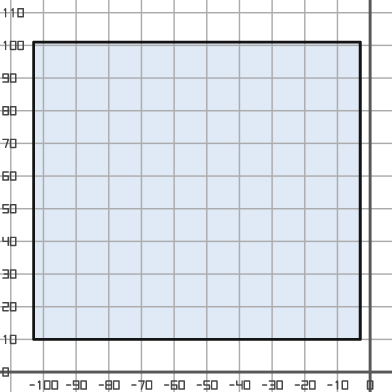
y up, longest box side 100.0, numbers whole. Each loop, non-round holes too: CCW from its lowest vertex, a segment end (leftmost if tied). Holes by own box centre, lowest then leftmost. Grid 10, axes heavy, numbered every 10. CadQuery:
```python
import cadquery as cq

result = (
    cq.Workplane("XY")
    .moveTo(-103.0, 10.0)
    .lineTo(-3.0, 10.0)
    .lineTo(-3.0, 101.0)
    .lineTo(-103.0, 101.0)
    .close()
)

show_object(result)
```